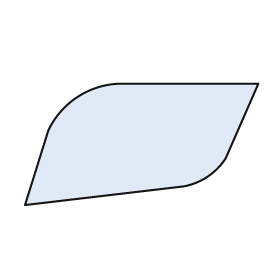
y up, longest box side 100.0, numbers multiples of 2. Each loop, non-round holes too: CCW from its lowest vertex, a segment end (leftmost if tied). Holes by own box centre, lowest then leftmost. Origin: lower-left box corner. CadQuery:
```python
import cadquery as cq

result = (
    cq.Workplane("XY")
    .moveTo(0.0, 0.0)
    .lineTo(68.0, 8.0)
    .threePointArc((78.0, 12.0), (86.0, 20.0))
    .lineTo(100.0, 52.0)
    .lineTo(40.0, 52.0)
    .threePointArc((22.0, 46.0), (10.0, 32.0))
    .close()
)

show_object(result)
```